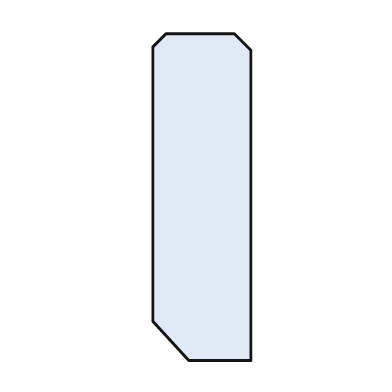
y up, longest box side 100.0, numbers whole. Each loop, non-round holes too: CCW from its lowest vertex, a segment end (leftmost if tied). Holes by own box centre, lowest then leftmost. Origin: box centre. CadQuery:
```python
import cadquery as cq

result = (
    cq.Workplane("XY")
    .moveTo(-4.0, -50.0)
    .lineTo(15.0, -50.0)
    .lineTo(15.0, 45.0)
    .lineTo(10.0, 50.0)
    .lineTo(-11.0, 50.0)
    .lineTo(-15.0, 46.0)
    .lineTo(-15.0, -38.0)
    .close()
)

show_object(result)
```